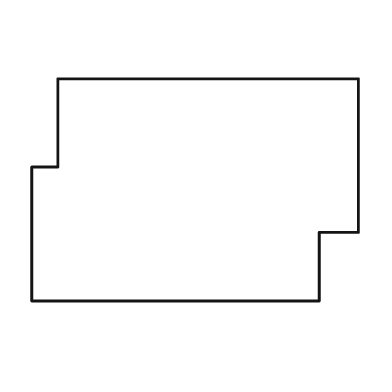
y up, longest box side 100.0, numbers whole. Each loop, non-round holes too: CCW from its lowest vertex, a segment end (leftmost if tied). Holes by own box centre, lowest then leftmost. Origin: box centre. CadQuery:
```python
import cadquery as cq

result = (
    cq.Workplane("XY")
    .moveTo(-50.0, -34.0)
    .lineTo(38.0, -34.0)
    .lineTo(38.0, -13.0)
    .lineTo(50.0, -13.0)
    .lineTo(50.0, 34.0)
    .lineTo(-42.0, 34.0)
    .lineTo(-42.0, 7.0)
    .lineTo(-50.0, 7.0)
    .close()
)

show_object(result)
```